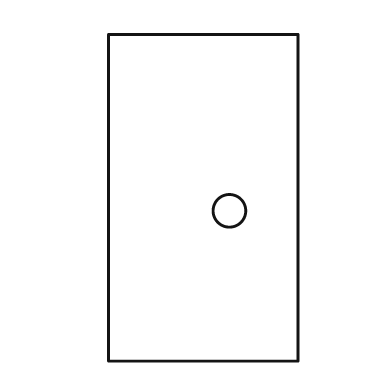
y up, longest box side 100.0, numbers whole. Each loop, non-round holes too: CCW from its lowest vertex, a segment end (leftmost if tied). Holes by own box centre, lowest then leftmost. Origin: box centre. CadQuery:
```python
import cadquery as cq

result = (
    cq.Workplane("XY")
    .moveTo(-29.0, -50.0)
    .lineTo(29.0, -50.0)
    .lineTo(29.0, 50.0)
    .lineTo(-29.0, 50.0)
    .close()
    .moveTo(8.0, -4.0)
    .circle(5.0)
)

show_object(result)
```